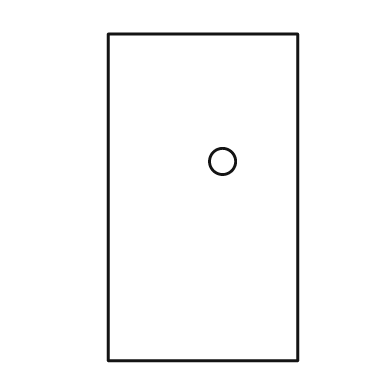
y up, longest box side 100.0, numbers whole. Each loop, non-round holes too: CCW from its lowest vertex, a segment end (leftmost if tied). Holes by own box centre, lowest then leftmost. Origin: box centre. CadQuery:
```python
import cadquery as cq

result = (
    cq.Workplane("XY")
    .moveTo(-29.0, -50.0)
    .lineTo(29.0, -50.0)
    .lineTo(29.0, 50.0)
    .lineTo(-29.0, 50.0)
    .close()
    .moveTo(6.0, 11.0)
    .circle(4.0)
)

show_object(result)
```